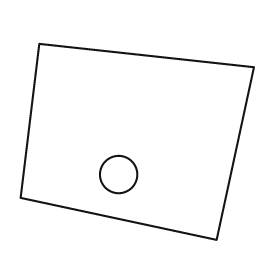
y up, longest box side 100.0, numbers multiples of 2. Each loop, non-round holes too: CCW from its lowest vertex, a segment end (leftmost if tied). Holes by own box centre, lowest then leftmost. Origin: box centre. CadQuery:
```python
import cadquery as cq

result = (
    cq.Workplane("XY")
    .moveTo(34.0, -42.0)
    .lineTo(50.0, 32.0)
    .lineTo(-42.0, 42.0)
    .lineTo(-50.0, -24.0)
    .close()
    .moveTo(-8.0, -14.0)
    .circle(8.0)
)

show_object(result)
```